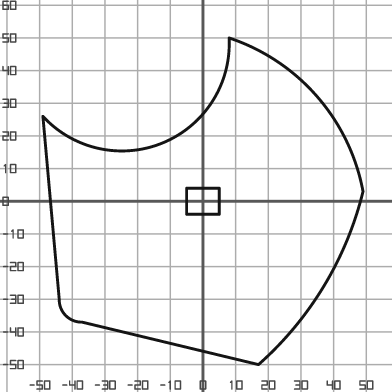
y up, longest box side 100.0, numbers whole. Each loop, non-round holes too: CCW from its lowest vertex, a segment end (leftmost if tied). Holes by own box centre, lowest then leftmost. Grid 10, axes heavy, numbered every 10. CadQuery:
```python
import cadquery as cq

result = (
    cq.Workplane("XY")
    .moveTo(17.0, -50.0)
    .threePointArc((37.0, -26.0), (49.0, 3.0))
    .threePointArc((35.0, 32.0), (8.0, 50.0))
    .threePointArc((-12.0, 18.0), (-49.0, 26.0))
    .lineTo(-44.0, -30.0)
    .threePointArc((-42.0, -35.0), (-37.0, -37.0))
    .close()
    .moveTo(-5.0, -4.0)
    .lineTo(5.0, -4.0)
    .lineTo(5.0, 4.0)
    .lineTo(-5.0, 4.0)
    .close()
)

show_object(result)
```